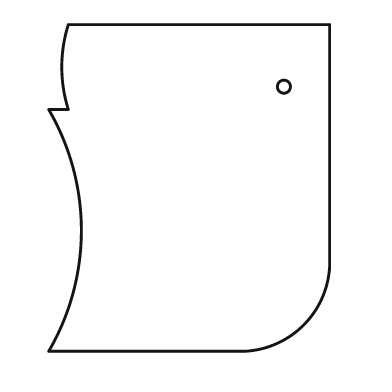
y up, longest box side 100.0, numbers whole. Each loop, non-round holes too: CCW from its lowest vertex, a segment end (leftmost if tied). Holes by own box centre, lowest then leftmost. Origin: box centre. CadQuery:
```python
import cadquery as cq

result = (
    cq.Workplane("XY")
    .moveTo(-43.0, -50.0)
    .lineTo(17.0, -50.0)
    .threePointArc((35.0, -42.0), (43.0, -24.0))
    .lineTo(43.0, 50.0)
    .lineTo(-37.0, 50.0)
    .threePointArc((-39.0, 37.0), (-37.0, 24.0))
    .lineTo(-43.0, 24.0)
    .threePointArc((-33.0, -13.0), (-43.0, -50.0))
    .close()
    .moveTo(29.0, 31.0)
    .circle(2.0)
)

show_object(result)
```